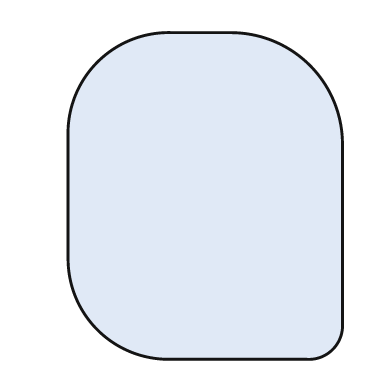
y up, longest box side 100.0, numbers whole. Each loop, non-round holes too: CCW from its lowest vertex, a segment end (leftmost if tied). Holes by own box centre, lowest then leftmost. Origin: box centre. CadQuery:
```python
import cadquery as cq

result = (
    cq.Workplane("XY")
    .moveTo(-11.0, -50.0)
    .lineTo(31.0, -50.0)
    .threePointArc((39.0, -47.0), (42.0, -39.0))
    .lineTo(42.0, 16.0)
    .threePointArc((32.0, 40.0), (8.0, 50.0))
    .lineTo(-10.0, 50.0)
    .threePointArc((-33.0, 41.0), (-42.0, 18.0))
    .lineTo(-42.0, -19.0)
    .threePointArc((-33.0, -41.0), (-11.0, -50.0))
    .close()
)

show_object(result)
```